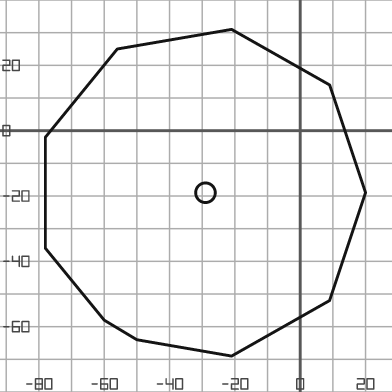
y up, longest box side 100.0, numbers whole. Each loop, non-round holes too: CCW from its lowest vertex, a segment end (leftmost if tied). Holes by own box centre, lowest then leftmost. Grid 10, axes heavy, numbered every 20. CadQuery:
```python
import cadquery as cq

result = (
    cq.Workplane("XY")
    .moveTo(-21.0, -69.0)
    .lineTo(9.0, -52.0)
    .lineTo(20.0, -19.0)
    .lineTo(9.0, 14.0)
    .lineTo(-21.0, 31.0)
    .lineTo(-56.0, 25.0)
    .lineTo(-78.0, -2.0)
    .lineTo(-78.0, -36.0)
    .lineTo(-60.0, -58.0)
    .lineTo(-50.0, -64.0)
    .close()
    .moveTo(-29.0, -19.0)
    .circle(3.0)
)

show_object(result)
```